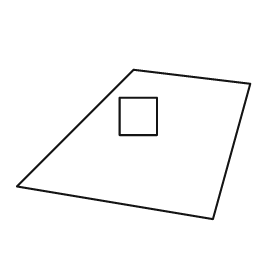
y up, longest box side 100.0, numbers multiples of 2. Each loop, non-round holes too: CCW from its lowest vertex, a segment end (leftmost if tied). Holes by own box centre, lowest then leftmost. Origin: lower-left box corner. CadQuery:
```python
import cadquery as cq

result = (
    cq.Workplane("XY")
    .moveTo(84.0, 0.0)
    .lineTo(100.0, 58.0)
    .lineTo(50.0, 64.0)
    .lineTo(0.0, 14.0)
    .close()
    .moveTo(44.0, 36.0)
    .lineTo(60.0, 36.0)
    .lineTo(60.0, 52.0)
    .lineTo(44.0, 52.0)
    .close()
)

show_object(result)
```